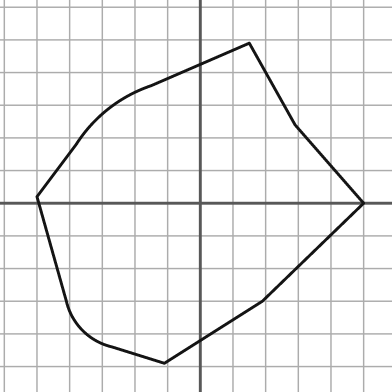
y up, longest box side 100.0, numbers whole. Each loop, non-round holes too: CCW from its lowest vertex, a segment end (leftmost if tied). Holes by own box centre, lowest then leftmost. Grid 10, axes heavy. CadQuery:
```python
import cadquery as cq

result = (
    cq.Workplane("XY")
    .moveTo(-11.0, -49.0)
    .lineTo(19.0, -30.0)
    .lineTo(50.0, 0.0)
    .lineTo(29.0, 24.0)
    .lineTo(15.0, 49.0)
    .lineTo(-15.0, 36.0)
    .threePointArc((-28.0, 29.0), (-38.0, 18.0))
    .lineTo(-50.0, 2.0)
    .lineTo(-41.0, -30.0)
    .threePointArc((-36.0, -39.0), (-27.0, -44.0))
    .close()
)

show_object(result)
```